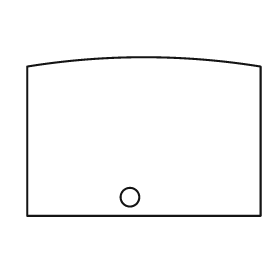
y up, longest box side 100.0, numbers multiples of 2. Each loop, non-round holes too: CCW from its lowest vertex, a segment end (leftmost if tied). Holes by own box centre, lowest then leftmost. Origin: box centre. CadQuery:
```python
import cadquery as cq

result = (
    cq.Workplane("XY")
    .moveTo(-50.0, -34.0)
    .lineTo(50.0, -34.0)
    .lineTo(50.0, 30.0)
    .threePointArc((0.0, 34.0), (-50.0, 30.0))
    .close()
    .moveTo(-6.0, -26.0)
    .circle(4.0)
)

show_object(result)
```